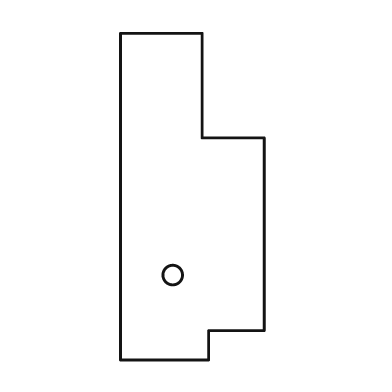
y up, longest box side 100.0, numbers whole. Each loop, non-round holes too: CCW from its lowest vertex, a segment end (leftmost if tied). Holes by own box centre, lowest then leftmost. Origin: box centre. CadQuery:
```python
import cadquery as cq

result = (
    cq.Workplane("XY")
    .moveTo(-22.0, -50.0)
    .lineTo(5.0, -50.0)
    .lineTo(5.0, -41.0)
    .lineTo(22.0, -41.0)
    .lineTo(22.0, 18.0)
    .lineTo(3.0, 18.0)
    .lineTo(3.0, 50.0)
    .lineTo(-22.0, 50.0)
    .close()
    .moveTo(-6.0, -24.0)
    .circle(3.0)
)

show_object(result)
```